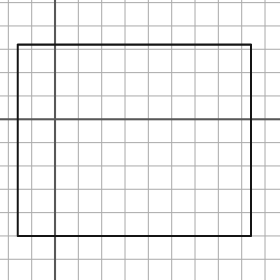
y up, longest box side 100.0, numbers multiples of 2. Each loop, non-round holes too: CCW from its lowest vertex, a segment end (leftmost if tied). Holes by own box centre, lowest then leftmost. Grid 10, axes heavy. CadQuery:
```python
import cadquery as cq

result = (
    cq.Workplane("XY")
    .moveTo(-16.0, -50.0)
    .lineTo(84.0, -50.0)
    .lineTo(84.0, 32.0)
    .lineTo(-16.0, 32.0)
    .close()
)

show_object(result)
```